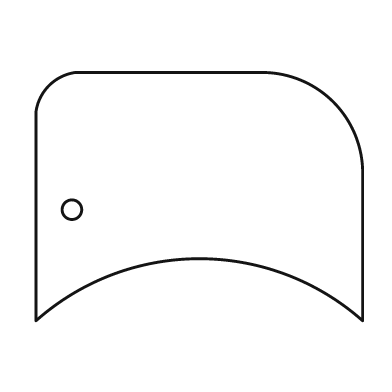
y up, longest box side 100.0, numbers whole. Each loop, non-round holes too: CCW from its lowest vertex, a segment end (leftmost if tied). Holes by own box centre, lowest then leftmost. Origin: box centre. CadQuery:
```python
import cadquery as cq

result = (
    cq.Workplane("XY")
    .moveTo(-50.0, -38.0)
    .threePointArc((0.0, -19.0), (50.0, -38.0))
    .lineTo(50.0, 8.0)
    .threePointArc((41.0, 29.0), (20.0, 38.0))
    .lineTo(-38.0, 38.0)
    .threePointArc((-46.0, 34.0), (-50.0, 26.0))
    .close()
    .moveTo(-39.0, -4.0)
    .circle(3.0)
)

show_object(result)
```